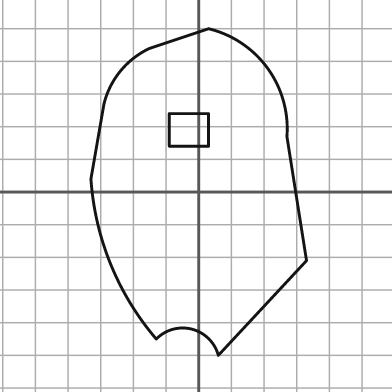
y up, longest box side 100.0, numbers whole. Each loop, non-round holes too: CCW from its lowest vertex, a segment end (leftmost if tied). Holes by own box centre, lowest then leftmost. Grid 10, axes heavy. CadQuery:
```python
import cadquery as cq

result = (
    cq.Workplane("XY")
    .moveTo(6.0, -50.0)
    .lineTo(33.0, -21.0)
    .lineTo(27.0, 17.0)
    .threePointArc((21.0, 38.0), (3.0, 50.0))
    .lineTo(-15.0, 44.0)
    .threePointArc((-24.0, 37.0), (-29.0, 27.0))
    .lineTo(-33.0, 4.0)
    .threePointArc((-27.0, -22.0), (-13.0, -45.0))
    .threePointArc((-2.0, -42.0), (6.0, -50.0))
    .close()
    .moveTo(-9.0, 14.0)
    .lineTo(3.0, 14.0)
    .lineTo(3.0, 24.0)
    .lineTo(-9.0, 24.0)
    .close()
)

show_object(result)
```